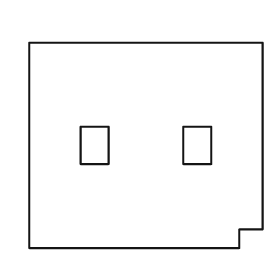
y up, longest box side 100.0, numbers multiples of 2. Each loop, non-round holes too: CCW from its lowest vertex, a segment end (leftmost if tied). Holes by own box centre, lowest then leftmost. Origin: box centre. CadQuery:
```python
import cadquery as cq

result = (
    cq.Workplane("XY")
    .moveTo(-50.0, -44.0)
    .lineTo(40.0, -44.0)
    .lineTo(40.0, -36.0)
    .lineTo(50.0, -36.0)
    .lineTo(50.0, 44.0)
    .lineTo(-50.0, 44.0)
    .close()
    .moveTo(-28.0, -8.0)
    .lineTo(-16.0, -8.0)
    .lineTo(-16.0, 8.0)
    .lineTo(-28.0, 8.0)
    .close()
    .moveTo(16.0, -8.0)
    .lineTo(28.0, -8.0)
    .lineTo(28.0, 8.0)
    .lineTo(16.0, 8.0)
    .close()
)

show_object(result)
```